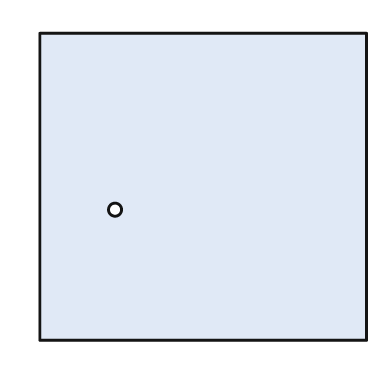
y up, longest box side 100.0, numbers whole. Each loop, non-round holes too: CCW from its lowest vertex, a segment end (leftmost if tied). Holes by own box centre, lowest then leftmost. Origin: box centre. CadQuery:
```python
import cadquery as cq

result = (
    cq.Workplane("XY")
    .moveTo(-50.0, -47.0)
    .lineTo(50.0, -47.0)
    .lineTo(50.0, 47.0)
    .lineTo(-50.0, 47.0)
    .close()
    .moveTo(-27.0, -7.0)
    .circle(2.0)
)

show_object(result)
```